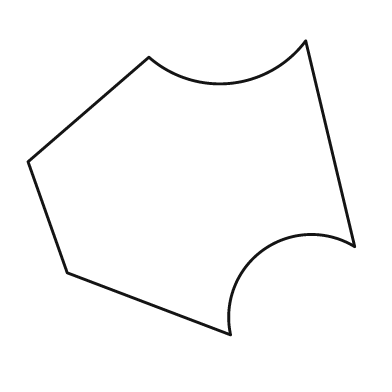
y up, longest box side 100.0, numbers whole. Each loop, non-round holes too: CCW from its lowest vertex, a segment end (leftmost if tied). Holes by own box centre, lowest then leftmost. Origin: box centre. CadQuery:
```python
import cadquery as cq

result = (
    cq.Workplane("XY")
    .moveTo(12.0, -45.0)
    .threePointArc((22.0, -19.0), (50.0, -18.0))
    .lineTo(35.0, 45.0)
    .threePointArc((12.0, 32.0), (-13.0, 40.0))
    .lineTo(-50.0, 8.0)
    .lineTo(-38.0, -26.0)
    .close()
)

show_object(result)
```